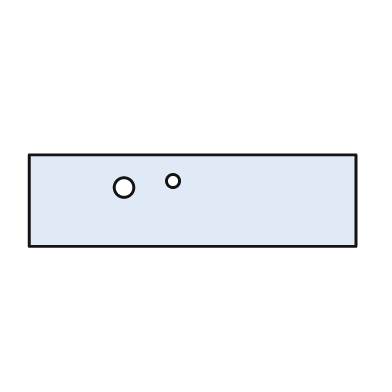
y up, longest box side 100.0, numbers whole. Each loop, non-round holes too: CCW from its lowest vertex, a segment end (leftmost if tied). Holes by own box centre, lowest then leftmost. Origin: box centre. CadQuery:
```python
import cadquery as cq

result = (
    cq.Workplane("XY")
    .moveTo(-50.0, -14.0)
    .lineTo(50.0, -14.0)
    .lineTo(50.0, 14.0)
    .lineTo(-50.0, 14.0)
    .close()
    .moveTo(-21.0, 4.0)
    .circle(3.0)
    .moveTo(-6.0, 6.0)
    .circle(2.0)
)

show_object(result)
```